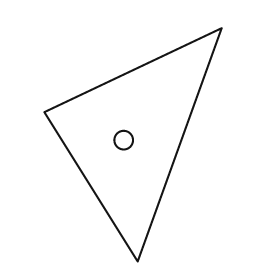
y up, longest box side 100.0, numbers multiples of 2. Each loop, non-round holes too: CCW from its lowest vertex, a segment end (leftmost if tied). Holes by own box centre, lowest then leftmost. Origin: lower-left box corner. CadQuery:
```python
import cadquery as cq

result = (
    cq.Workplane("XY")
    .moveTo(40.0, 0.0)
    .lineTo(76.0, 100.0)
    .lineTo(0.0, 64.0)
    .close()
    .moveTo(34.0, 52.0)
    .circle(4.0)
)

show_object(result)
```